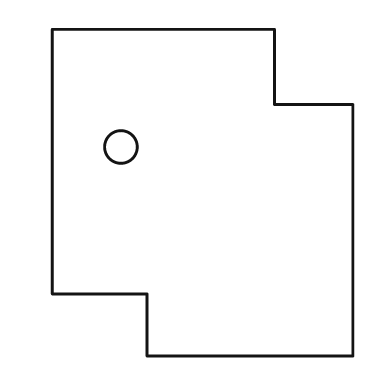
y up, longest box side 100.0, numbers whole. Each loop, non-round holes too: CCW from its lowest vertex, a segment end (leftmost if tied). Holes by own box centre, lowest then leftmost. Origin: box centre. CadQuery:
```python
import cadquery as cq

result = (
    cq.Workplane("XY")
    .moveTo(-17.0, -50.0)
    .lineTo(46.0, -50.0)
    .lineTo(46.0, 27.0)
    .lineTo(22.0, 27.0)
    .lineTo(22.0, 50.0)
    .lineTo(-46.0, 50.0)
    .lineTo(-46.0, -31.0)
    .lineTo(-17.0, -31.0)
    .close()
    .moveTo(-25.0, 14.0)
    .circle(5.0)
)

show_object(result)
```